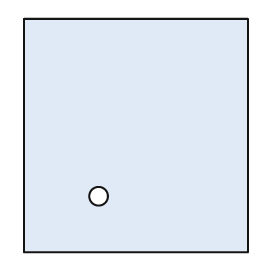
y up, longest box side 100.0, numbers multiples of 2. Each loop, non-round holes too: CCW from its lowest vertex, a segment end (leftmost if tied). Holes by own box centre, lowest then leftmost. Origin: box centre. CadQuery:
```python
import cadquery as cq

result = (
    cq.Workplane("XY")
    .moveTo(-48.0, -50.0)
    .lineTo(48.0, -50.0)
    .lineTo(48.0, 50.0)
    .lineTo(-48.0, 50.0)
    .close()
    .moveTo(-16.0, -26.0)
    .circle(4.0)
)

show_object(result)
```